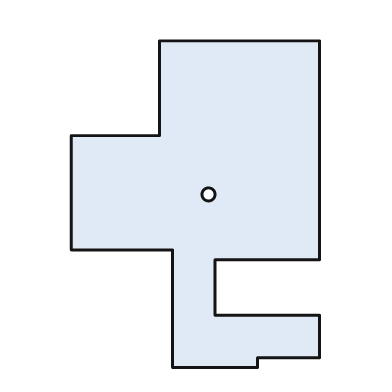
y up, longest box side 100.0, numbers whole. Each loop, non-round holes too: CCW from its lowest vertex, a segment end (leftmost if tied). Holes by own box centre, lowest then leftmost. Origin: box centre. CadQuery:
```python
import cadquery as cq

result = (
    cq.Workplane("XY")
    .moveTo(-7.0, -50.0)
    .lineTo(19.0, -50.0)
    .lineTo(19.0, -47.0)
    .lineTo(38.0, -47.0)
    .lineTo(38.0, -34.0)
    .lineTo(6.0, -34.0)
    .lineTo(6.0, -17.0)
    .lineTo(38.0, -17.0)
    .lineTo(38.0, 50.0)
    .lineTo(-11.0, 50.0)
    .lineTo(-11.0, 21.0)
    .lineTo(-38.0, 21.0)
    .lineTo(-38.0, -14.0)
    .lineTo(-7.0, -14.0)
    .close()
    .moveTo(4.0, 3.0)
    .circle(2.0)
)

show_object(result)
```